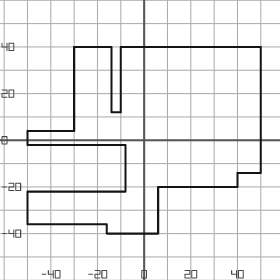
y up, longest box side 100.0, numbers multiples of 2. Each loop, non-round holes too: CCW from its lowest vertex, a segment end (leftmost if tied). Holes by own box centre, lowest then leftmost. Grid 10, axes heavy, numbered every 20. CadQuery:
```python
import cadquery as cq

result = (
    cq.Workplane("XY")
    .moveTo(-16.0, -40.0)
    .lineTo(6.0, -40.0)
    .lineTo(6.0, -20.0)
    .lineTo(40.0, -20.0)
    .lineTo(40.0, -14.0)
    .lineTo(50.0, -14.0)
    .lineTo(50.0, 40.0)
    .lineTo(-10.0, 40.0)
    .lineTo(-10.0, 12.0)
    .lineTo(-14.0, 12.0)
    .lineTo(-14.0, 40.0)
    .lineTo(-30.0, 40.0)
    .lineTo(-30.0, 4.0)
    .lineTo(-50.0, 4.0)
    .lineTo(-50.0, -2.0)
    .lineTo(-8.0, -2.0)
    .lineTo(-8.0, -22.0)
    .lineTo(-50.0, -22.0)
    .lineTo(-50.0, -36.0)
    .lineTo(-16.0, -36.0)
    .close()
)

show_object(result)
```